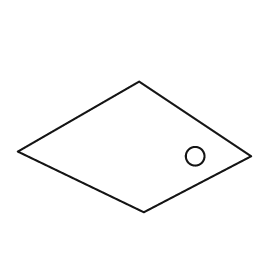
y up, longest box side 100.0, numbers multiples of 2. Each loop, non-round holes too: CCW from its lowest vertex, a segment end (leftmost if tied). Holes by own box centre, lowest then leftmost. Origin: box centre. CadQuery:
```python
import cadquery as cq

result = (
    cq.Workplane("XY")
    .moveTo(4.0, -28.0)
    .lineTo(50.0, -4.0)
    .lineTo(2.0, 28.0)
    .lineTo(-50.0, -2.0)
    .close()
    .moveTo(26.0, -4.0)
    .circle(4.0)
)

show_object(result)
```